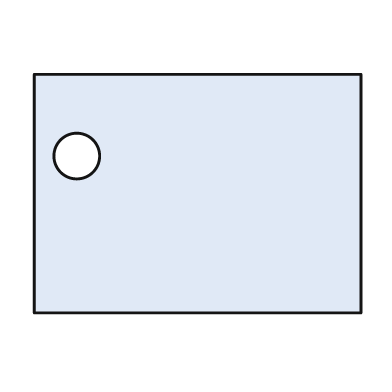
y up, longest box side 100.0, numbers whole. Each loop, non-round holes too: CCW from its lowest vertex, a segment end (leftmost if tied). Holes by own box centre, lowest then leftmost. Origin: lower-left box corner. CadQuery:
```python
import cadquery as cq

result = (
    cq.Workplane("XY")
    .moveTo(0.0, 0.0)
    .lineTo(100.0, 0.0)
    .lineTo(100.0, 73.0)
    .lineTo(0.0, 73.0)
    .close()
    .moveTo(13.0, 48.0)
    .circle(7.0)
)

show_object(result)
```